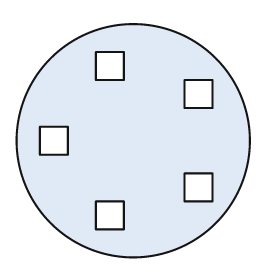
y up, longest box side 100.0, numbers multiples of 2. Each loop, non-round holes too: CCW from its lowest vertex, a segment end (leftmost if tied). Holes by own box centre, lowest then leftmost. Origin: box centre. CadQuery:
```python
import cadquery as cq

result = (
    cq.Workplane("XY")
    .moveTo(0.0, 0.0)
    .circle(50.0)
    .moveTo(-16.0, -38.0)
    .lineTo(-4.0, -38.0)
    .lineTo(-4.0, -26.0)
    .lineTo(-16.0, -26.0)
    .close()
    .moveTo(22.0, -26.0)
    .lineTo(34.0, -26.0)
    .lineTo(34.0, -14.0)
    .lineTo(22.0, -14.0)
    .close()
    .moveTo(-40.0, -6.0)
    .lineTo(-28.0, -6.0)
    .lineTo(-28.0, 6.0)
    .lineTo(-40.0, 6.0)
    .close()
    .moveTo(22.0, 14.0)
    .lineTo(34.0, 14.0)
    .lineTo(34.0, 26.0)
    .lineTo(22.0, 26.0)
    .close()
    .moveTo(-16.0, 26.0)
    .lineTo(-4.0, 26.0)
    .lineTo(-4.0, 38.0)
    .lineTo(-16.0, 38.0)
    .close()
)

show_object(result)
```